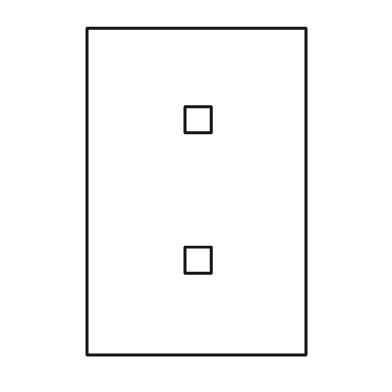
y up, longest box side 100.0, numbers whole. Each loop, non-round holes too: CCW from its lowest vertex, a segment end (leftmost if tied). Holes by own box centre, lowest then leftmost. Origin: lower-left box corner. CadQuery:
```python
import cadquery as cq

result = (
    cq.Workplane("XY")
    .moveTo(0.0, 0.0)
    .lineTo(67.0, 0.0)
    .lineTo(67.0, 100.0)
    .lineTo(0.0, 100.0)
    .close()
    .moveTo(30.0, 25.0)
    .lineTo(38.0, 25.0)
    .lineTo(38.0, 33.0)
    .lineTo(30.0, 33.0)
    .close()
    .moveTo(30.0, 68.0)
    .lineTo(38.0, 68.0)
    .lineTo(38.0, 76.0)
    .lineTo(30.0, 76.0)
    .close()
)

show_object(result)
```